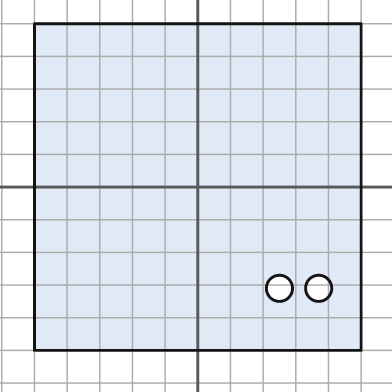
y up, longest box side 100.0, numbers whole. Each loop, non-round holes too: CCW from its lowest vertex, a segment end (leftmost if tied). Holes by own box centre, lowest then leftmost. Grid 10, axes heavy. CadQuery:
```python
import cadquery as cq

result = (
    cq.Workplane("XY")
    .moveTo(-50.0, -50.0)
    .lineTo(50.0, -50.0)
    .lineTo(50.0, 50.0)
    .lineTo(-50.0, 50.0)
    .close()
    .moveTo(25.0, -31.0)
    .circle(4.0)
    .moveTo(37.0, -31.0)
    .circle(4.0)
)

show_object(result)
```